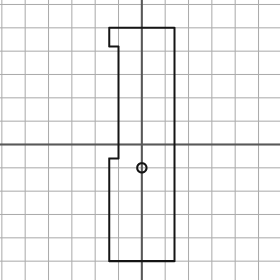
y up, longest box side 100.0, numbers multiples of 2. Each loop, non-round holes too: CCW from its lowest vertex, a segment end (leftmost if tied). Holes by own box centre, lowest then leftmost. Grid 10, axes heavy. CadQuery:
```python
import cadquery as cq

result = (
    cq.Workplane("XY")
    .moveTo(-14.0, -50.0)
    .lineTo(14.0, -50.0)
    .lineTo(14.0, 50.0)
    .lineTo(-14.0, 50.0)
    .lineTo(-14.0, 42.0)
    .lineTo(-10.0, 42.0)
    .lineTo(-10.0, -6.0)
    .lineTo(-14.0, -6.0)
    .close()
    .moveTo(0.0, -10.0)
    .circle(2.0)
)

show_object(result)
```